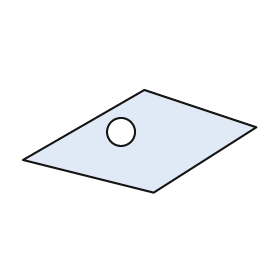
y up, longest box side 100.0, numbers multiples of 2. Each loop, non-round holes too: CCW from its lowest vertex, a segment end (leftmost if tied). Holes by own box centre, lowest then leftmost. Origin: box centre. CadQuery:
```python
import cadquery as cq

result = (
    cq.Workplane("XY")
    .moveTo(6.0, -22.0)
    .lineTo(50.0, 6.0)
    .lineTo(2.0, 22.0)
    .lineTo(-50.0, -8.0)
    .close()
    .moveTo(-8.0, 4.0)
    .circle(6.0)
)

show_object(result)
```